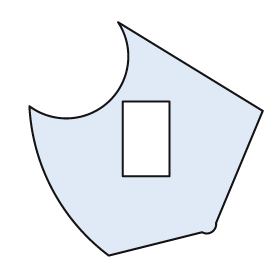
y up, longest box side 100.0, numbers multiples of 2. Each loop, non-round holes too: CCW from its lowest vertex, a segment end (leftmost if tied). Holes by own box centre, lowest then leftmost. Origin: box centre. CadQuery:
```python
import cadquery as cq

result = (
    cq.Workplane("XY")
    .moveTo(-16.0, -50.0)
    .lineTo(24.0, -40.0)
    .threePointArc((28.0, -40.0), (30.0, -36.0))
    .lineTo(50.0, 12.0)
    .lineTo(-12.0, 50.0)
    .threePointArc((-16.0, 16.0), (-50.0, 14.0))
    .threePointArc((-40.0, -22.0), (-16.0, -50.0))
    .close()
    .moveTo(-10.0, -16.0)
    .lineTo(10.0, -16.0)
    .lineTo(10.0, 16.0)
    .lineTo(-10.0, 16.0)
    .close()
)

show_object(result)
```